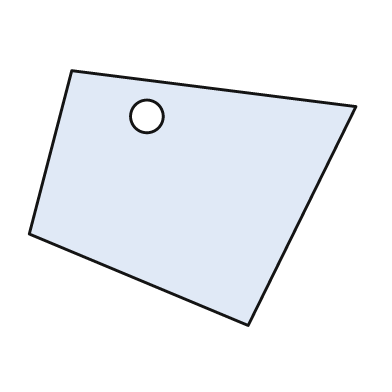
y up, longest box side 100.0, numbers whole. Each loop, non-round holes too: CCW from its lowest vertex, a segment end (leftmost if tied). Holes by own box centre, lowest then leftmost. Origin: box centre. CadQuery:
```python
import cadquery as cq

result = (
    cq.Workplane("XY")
    .moveTo(17.0, -39.0)
    .lineTo(50.0, 28.0)
    .lineTo(-37.0, 39.0)
    .lineTo(-50.0, -11.0)
    .close()
    .moveTo(-14.0, 25.0)
    .circle(5.0)
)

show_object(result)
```